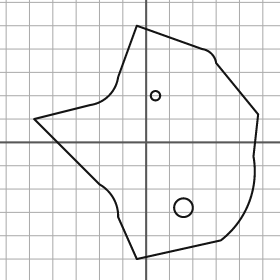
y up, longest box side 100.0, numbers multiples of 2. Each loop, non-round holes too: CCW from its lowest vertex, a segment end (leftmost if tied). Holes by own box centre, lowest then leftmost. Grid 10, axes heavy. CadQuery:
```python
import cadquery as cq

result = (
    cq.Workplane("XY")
    .moveTo(-4.0, -50.0)
    .lineTo(32.0, -42.0)
    .threePointArc((44.0, -26.0), (46.0, -6.0))
    .lineTo(48.0, 12.0)
    .lineTo(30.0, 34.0)
    .threePointArc((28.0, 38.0), (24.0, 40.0))
    .lineTo(-4.0, 50.0)
    .lineTo(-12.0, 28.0)
    .threePointArc((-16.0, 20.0), (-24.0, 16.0))
    .lineTo(-48.0, 10.0)
    .lineTo(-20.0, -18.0)
    .threePointArc((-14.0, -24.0), (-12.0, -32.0))
    .close()
    .moveTo(16.0, -28.0)
    .circle(4.0)
    .moveTo(4.0, 20.0)
    .circle(2.0)
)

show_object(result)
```